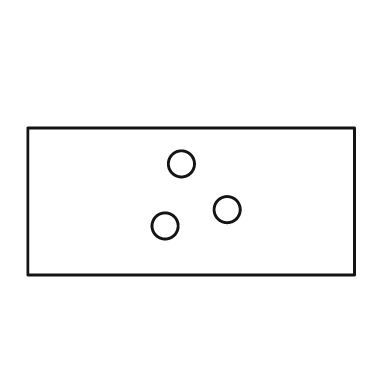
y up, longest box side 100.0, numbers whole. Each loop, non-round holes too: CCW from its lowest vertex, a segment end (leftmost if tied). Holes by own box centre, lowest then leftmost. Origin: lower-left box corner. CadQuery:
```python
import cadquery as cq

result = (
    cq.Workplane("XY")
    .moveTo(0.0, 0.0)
    .lineTo(100.0, 0.0)
    .lineTo(100.0, 45.0)
    .lineTo(0.0, 45.0)
    .close()
    .moveTo(42.0, 15.0)
    .circle(4.0)
    .moveTo(61.0, 20.0)
    .circle(4.0)
    .moveTo(47.0, 34.0)
    .circle(4.0)
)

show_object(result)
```